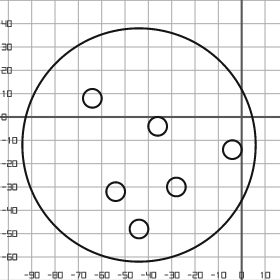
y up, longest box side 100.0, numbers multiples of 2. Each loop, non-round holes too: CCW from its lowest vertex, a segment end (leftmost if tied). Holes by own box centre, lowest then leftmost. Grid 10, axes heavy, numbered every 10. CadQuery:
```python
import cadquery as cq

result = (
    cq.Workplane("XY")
    .moveTo(-44.0, -12.0)
    .circle(50.0)
    .moveTo(-44.0, -48.0)
    .circle(4.0)
    .moveTo(-54.0, -32.0)
    .circle(4.0)
    .moveTo(-28.0, -30.0)
    .circle(4.0)
    .moveTo(-4.0, -14.0)
    .circle(4.0)
    .moveTo(-36.0, -4.0)
    .circle(4.0)
    .moveTo(-64.0, 8.0)
    .circle(4.0)
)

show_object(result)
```